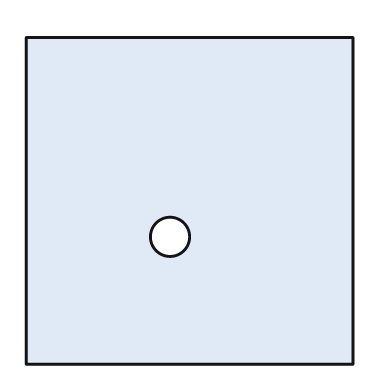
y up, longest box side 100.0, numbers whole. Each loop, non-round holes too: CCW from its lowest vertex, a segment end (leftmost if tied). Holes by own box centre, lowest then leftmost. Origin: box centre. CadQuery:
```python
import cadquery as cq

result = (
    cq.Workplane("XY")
    .moveTo(-50.0, -50.0)
    .lineTo(50.0, -50.0)
    .lineTo(50.0, 50.0)
    .lineTo(-50.0, 50.0)
    .close()
    .moveTo(-6.0, -11.0)
    .circle(6.0)
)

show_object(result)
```